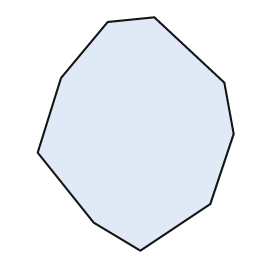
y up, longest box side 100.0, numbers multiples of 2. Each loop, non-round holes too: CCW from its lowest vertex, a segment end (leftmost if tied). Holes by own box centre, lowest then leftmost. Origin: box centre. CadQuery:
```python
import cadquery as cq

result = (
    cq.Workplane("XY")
    .moveTo(2.0, -50.0)
    .lineTo(32.0, -30.0)
    .lineTo(42.0, 0.0)
    .lineTo(38.0, 22.0)
    .lineTo(8.0, 50.0)
    .lineTo(-12.0, 48.0)
    .lineTo(-32.0, 24.0)
    .lineTo(-42.0, -8.0)
    .lineTo(-18.0, -38.0)
    .close()
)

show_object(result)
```